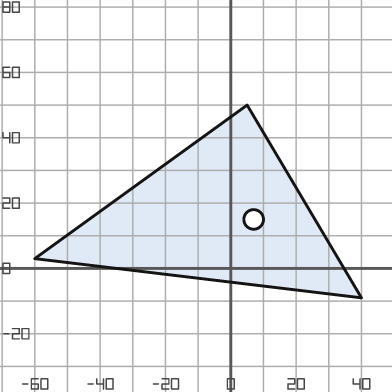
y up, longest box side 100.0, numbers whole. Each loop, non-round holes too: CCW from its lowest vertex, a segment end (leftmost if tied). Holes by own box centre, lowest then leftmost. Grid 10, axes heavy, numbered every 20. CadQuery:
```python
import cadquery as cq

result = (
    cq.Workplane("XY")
    .moveTo(40.0, -9.0)
    .lineTo(5.0, 50.0)
    .lineTo(-60.0, 3.0)
    .close()
    .moveTo(7.0, 15.0)
    .circle(3.0)
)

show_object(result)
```